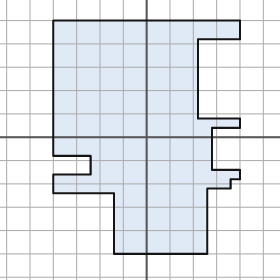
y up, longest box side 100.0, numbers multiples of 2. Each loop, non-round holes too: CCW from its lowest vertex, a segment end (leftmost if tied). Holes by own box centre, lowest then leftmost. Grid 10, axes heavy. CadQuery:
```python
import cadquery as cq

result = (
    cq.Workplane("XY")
    .moveTo(-14.0, -50.0)
    .lineTo(26.0, -50.0)
    .lineTo(26.0, -22.0)
    .lineTo(36.0, -22.0)
    .lineTo(36.0, -18.0)
    .lineTo(40.0, -18.0)
    .lineTo(40.0, -14.0)
    .lineTo(28.0, -14.0)
    .lineTo(28.0, 4.0)
    .lineTo(40.0, 4.0)
    .lineTo(40.0, 8.0)
    .lineTo(22.0, 8.0)
    .lineTo(22.0, 42.0)
    .lineTo(40.0, 42.0)
    .lineTo(40.0, 50.0)
    .lineTo(-40.0, 50.0)
    .lineTo(-40.0, -8.0)
    .lineTo(-24.0, -8.0)
    .lineTo(-24.0, -16.0)
    .lineTo(-40.0, -16.0)
    .lineTo(-40.0, -24.0)
    .lineTo(-14.0, -24.0)
    .close()
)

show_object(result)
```